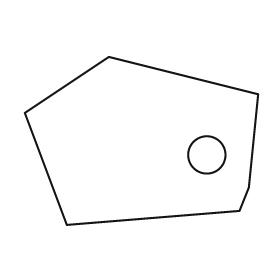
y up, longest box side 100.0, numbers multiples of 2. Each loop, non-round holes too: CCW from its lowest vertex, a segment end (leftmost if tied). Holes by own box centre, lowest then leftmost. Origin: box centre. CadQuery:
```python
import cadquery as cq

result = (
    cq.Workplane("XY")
    .moveTo(-32.0, -36.0)
    .lineTo(42.0, -30.0)
    .lineTo(46.0, -20.0)
    .lineTo(50.0, 20.0)
    .lineTo(-14.0, 36.0)
    .lineTo(-50.0, 12.0)
    .close()
    .moveTo(28.0, -6.0)
    .circle(8.0)
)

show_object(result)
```